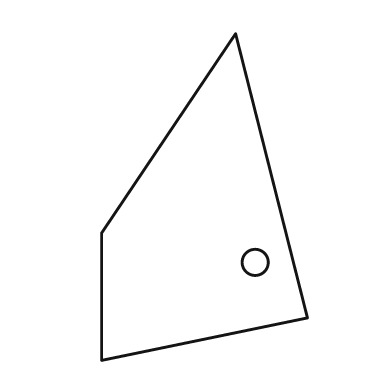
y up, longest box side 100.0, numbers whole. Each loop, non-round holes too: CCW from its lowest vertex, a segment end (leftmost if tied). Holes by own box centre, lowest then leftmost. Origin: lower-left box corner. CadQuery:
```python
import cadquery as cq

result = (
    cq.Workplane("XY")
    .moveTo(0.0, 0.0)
    .lineTo(63.0, 13.0)
    .lineTo(41.0, 100.0)
    .lineTo(0.0, 39.0)
    .close()
    .moveTo(47.0, 30.0)
    .circle(4.0)
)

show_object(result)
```